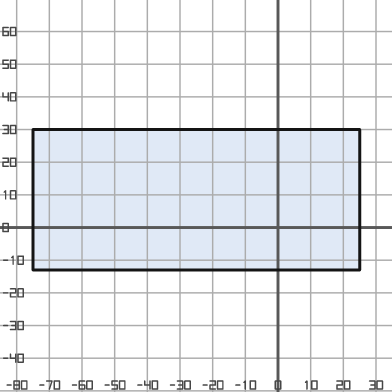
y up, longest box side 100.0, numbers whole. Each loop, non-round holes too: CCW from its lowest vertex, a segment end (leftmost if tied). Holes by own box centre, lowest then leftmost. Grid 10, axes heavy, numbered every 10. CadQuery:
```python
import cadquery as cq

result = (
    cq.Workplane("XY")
    .moveTo(-75.0, -13.0)
    .lineTo(25.0, -13.0)
    .lineTo(25.0, 30.0)
    .lineTo(-75.0, 30.0)
    .close()
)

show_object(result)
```